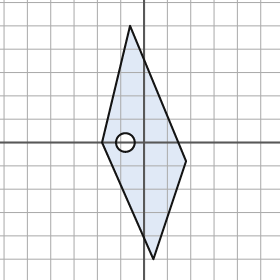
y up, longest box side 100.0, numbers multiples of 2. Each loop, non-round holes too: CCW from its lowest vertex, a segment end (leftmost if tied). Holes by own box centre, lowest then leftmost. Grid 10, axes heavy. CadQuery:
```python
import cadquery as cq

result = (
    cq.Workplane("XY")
    .moveTo(4.0, -50.0)
    .lineTo(18.0, -8.0)
    .lineTo(-6.0, 50.0)
    .lineTo(-18.0, 0.0)
    .close()
    .moveTo(-8.0, 0.0)
    .circle(4.0)
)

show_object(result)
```